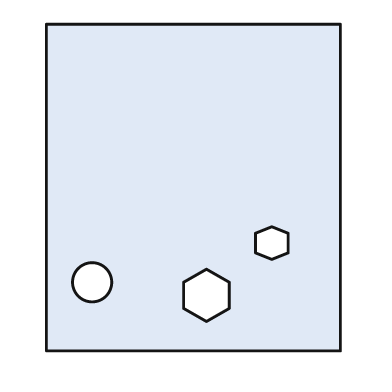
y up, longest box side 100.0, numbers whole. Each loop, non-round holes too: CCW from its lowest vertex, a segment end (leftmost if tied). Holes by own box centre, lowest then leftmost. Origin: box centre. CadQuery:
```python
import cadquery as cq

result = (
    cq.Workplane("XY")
    .moveTo(-45.0, -50.0)
    .lineTo(45.0, -50.0)
    .lineTo(45.0, 50.0)
    .lineTo(-45.0, 50.0)
    .close()
    .moveTo(4.0, -41.0)
    .lineTo(11.0, -37.0)
    .lineTo(11.0, -29.0)
    .lineTo(4.0, -25.0)
    .lineTo(-3.0, -29.0)
    .lineTo(-3.0, -37.0)
    .close()
    .moveTo(-31.0, -29.0)
    .circle(6.0)
    .moveTo(24.0, -22.0)
    .lineTo(29.0, -20.0)
    .lineTo(29.0, -14.0)
    .lineTo(24.0, -12.0)
    .lineTo(19.0, -14.0)
    .lineTo(19.0, -20.0)
    .close()
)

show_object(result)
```